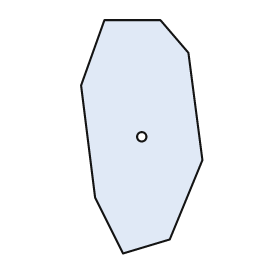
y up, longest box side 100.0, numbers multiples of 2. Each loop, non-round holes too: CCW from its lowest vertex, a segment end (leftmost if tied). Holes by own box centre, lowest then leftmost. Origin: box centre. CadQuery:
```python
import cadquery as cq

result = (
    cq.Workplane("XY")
    .moveTo(-8.0, -50.0)
    .lineTo(12.0, -44.0)
    .lineTo(26.0, -10.0)
    .lineTo(20.0, 36.0)
    .lineTo(8.0, 50.0)
    .lineTo(-16.0, 50.0)
    .lineTo(-26.0, 22.0)
    .lineTo(-20.0, -26.0)
    .close()
    .moveTo(0.0, 0.0)
    .circle(2.0)
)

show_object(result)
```